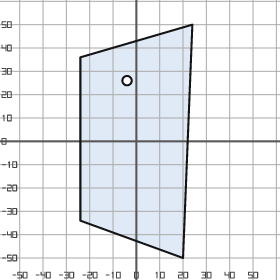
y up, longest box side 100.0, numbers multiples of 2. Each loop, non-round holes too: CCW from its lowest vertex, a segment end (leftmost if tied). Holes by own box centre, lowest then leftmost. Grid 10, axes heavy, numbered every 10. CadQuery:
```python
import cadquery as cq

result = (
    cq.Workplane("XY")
    .moveTo(20.0, -50.0)
    .lineTo(24.0, 50.0)
    .lineTo(-24.0, 36.0)
    .lineTo(-24.0, -34.0)
    .close()
    .moveTo(-4.0, 26.0)
    .circle(2.0)
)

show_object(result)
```